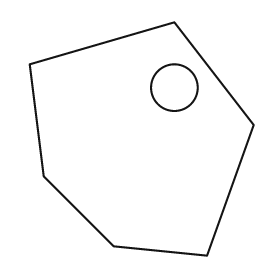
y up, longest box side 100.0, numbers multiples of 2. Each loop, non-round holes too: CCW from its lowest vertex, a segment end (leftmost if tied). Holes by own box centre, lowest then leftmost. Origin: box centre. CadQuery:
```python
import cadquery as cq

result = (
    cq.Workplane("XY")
    .moveTo(28.0, -50.0)
    .lineTo(48.0, 6.0)
    .lineTo(14.0, 50.0)
    .lineTo(-48.0, 32.0)
    .lineTo(-42.0, -16.0)
    .lineTo(-12.0, -46.0)
    .close()
    .moveTo(14.0, 22.0)
    .circle(10.0)
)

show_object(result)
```